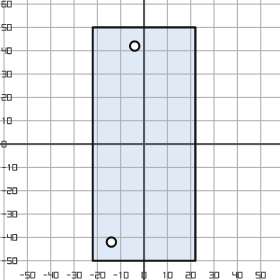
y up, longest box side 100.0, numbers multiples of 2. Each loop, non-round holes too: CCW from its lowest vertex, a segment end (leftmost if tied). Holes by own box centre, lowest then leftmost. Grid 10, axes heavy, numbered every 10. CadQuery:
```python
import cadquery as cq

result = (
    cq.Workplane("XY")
    .moveTo(-22.0, -50.0)
    .lineTo(22.0, -50.0)
    .lineTo(22.0, 50.0)
    .lineTo(-22.0, 50.0)
    .close()
    .moveTo(-14.0, -42.0)
    .circle(2.0)
    .moveTo(-4.0, 42.0)
    .circle(2.0)
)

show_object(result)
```